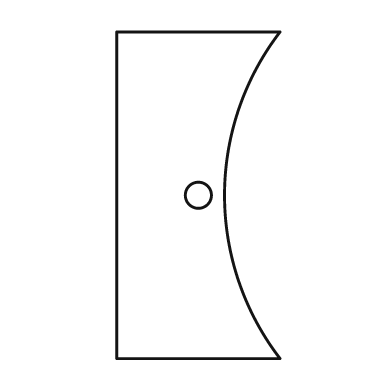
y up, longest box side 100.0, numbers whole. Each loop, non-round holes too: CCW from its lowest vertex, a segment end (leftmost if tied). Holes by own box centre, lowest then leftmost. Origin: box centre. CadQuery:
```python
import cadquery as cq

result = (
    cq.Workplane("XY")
    .moveTo(-25.0, -50.0)
    .lineTo(25.0, -50.0)
    .threePointArc((8.0, 0.0), (25.0, 50.0))
    .lineTo(-25.0, 50.0)
    .close()
    .moveTo(0.0, 0.0)
    .circle(4.0)
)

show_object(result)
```